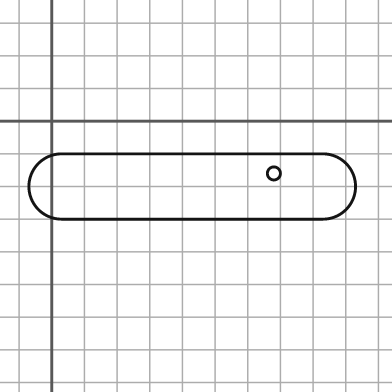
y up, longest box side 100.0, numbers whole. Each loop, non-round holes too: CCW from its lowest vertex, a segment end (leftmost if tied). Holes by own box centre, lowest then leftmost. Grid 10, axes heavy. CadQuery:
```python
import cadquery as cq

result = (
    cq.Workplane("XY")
    .moveTo(3.0, -30.0)
    .lineTo(83.0, -30.0)
    .threePointArc((93.0, -20.0), (83.0, -10.0))
    .lineTo(3.0, -10.0)
    .threePointArc((-7.0, -20.0), (3.0, -30.0))
    .close()
    .moveTo(68.0, -16.0)
    .circle(2.0)
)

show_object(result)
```